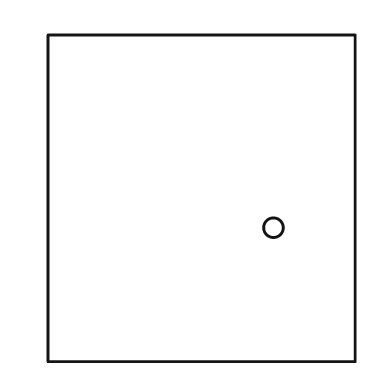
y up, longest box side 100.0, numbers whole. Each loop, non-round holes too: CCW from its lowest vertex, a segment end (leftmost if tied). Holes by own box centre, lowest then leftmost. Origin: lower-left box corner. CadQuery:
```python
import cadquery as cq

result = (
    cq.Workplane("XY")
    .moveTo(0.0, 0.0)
    .lineTo(94.0, 0.0)
    .lineTo(94.0, 100.0)
    .lineTo(0.0, 100.0)
    .close()
    .moveTo(69.0, 41.0)
    .circle(3.0)
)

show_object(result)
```